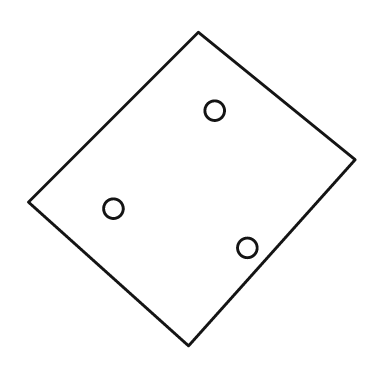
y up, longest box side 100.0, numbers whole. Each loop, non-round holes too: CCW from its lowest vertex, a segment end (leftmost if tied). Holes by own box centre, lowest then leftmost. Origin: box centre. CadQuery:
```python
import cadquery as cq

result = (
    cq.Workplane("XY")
    .moveTo(-1.0, -48.0)
    .lineTo(50.0, 9.0)
    .lineTo(2.0, 48.0)
    .lineTo(-50.0, -4.0)
    .close()
    .moveTo(17.0, -18.0)
    .circle(3.0)
    .moveTo(-24.0, -6.0)
    .circle(3.0)
    .moveTo(7.0, 24.0)
    .circle(3.0)
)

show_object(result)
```